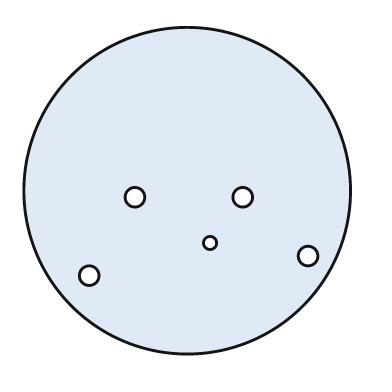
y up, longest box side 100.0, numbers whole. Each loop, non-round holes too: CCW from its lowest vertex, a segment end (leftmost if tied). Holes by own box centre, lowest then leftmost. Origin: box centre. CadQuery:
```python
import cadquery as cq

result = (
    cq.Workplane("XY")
    .moveTo(0.0, 0.0)
    .circle(50.0)
    .moveTo(-30.0, -26.0)
    .circle(3.0)
    .moveTo(37.0, -20.0)
    .circle(3.0)
    .moveTo(7.0, -16.0)
    .circle(2.0)
    .moveTo(-16.0, -2.0)
    .circle(3.0)
    .moveTo(17.0, -2.0)
    .circle(3.0)
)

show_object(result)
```